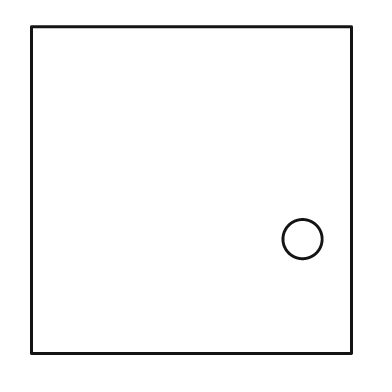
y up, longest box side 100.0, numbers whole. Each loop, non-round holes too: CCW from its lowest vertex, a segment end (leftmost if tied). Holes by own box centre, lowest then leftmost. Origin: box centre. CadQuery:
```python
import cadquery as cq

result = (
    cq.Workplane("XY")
    .moveTo(-49.0, -50.0)
    .lineTo(49.0, -50.0)
    .lineTo(49.0, 50.0)
    .lineTo(-49.0, 50.0)
    .close()
    .moveTo(34.0, -15.0)
    .circle(6.0)
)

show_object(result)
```